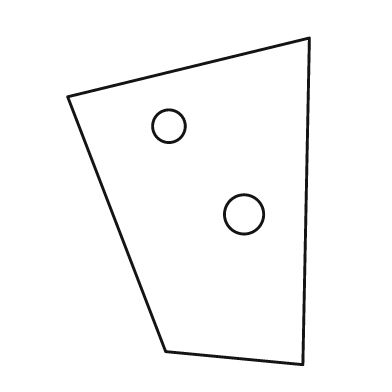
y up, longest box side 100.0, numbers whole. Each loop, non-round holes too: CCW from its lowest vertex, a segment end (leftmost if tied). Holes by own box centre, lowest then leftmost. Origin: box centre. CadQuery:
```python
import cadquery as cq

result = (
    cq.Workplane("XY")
    .moveTo(35.0, -50.0)
    .lineTo(37.0, 50.0)
    .lineTo(-37.0, 32.0)
    .lineTo(-7.0, -46.0)
    .close()
    .moveTo(17.0, -4.0)
    .circle(6.0)
    .moveTo(-6.0, 23.0)
    .circle(5.0)
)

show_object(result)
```